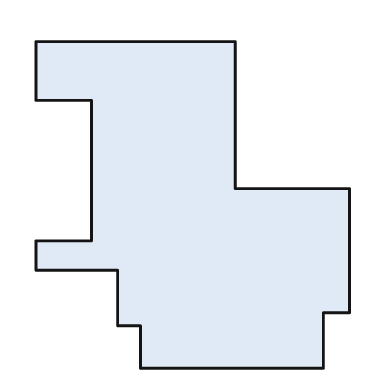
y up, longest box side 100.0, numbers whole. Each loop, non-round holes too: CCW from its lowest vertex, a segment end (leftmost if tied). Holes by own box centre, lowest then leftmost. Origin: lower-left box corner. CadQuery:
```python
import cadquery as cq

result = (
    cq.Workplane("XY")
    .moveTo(32.0, 0.0)
    .lineTo(88.0, 0.0)
    .lineTo(88.0, 17.0)
    .lineTo(96.0, 17.0)
    .lineTo(96.0, 55.0)
    .lineTo(61.0, 55.0)
    .lineTo(61.0, 100.0)
    .lineTo(0.0, 100.0)
    .lineTo(0.0, 82.0)
    .lineTo(17.0, 82.0)
    .lineTo(17.0, 39.0)
    .lineTo(0.0, 39.0)
    .lineTo(0.0, 30.0)
    .lineTo(25.0, 30.0)
    .lineTo(25.0, 13.0)
    .lineTo(32.0, 13.0)
    .close()
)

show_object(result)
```